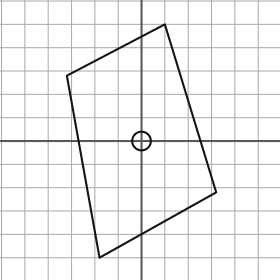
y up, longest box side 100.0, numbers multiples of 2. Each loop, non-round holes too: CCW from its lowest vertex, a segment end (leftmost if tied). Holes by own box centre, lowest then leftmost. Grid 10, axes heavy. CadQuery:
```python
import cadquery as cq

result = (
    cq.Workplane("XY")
    .moveTo(-18.0, -50.0)
    .lineTo(32.0, -22.0)
    .lineTo(10.0, 50.0)
    .lineTo(-32.0, 28.0)
    .close()
    .moveTo(0.0, 0.0)
    .circle(4.0)
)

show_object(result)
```